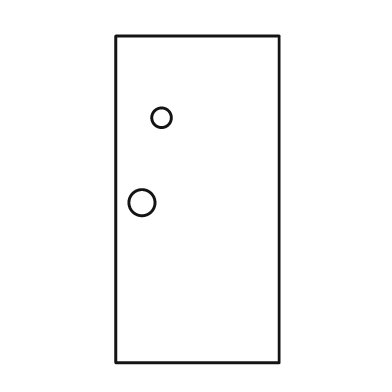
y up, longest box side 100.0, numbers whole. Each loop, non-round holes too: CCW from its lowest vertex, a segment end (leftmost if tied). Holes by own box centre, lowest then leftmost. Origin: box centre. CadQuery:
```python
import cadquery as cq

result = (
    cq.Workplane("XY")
    .moveTo(-25.0, -50.0)
    .lineTo(25.0, -50.0)
    .lineTo(25.0, 50.0)
    .lineTo(-25.0, 50.0)
    .close()
    .moveTo(-17.0, -1.0)
    .circle(4.0)
    .moveTo(-11.0, 25.0)
    .circle(3.0)
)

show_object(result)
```